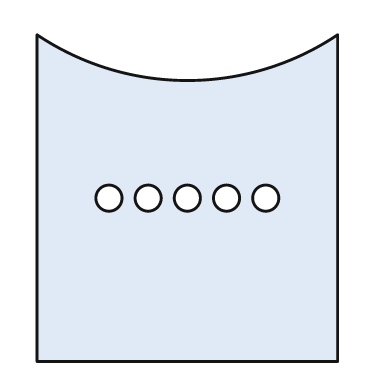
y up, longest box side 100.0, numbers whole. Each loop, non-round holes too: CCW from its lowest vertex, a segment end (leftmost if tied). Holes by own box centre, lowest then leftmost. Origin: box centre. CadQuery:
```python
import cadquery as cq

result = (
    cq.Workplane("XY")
    .moveTo(-46.0, -50.0)
    .lineTo(46.0, -50.0)
    .lineTo(46.0, 50.0)
    .threePointArc((0.0, 36.0), (-46.0, 50.0))
    .close()
    .moveTo(-24.0, 0.0)
    .circle(4.0)
    .moveTo(-12.0, 0.0)
    .circle(4.0)
    .moveTo(0.0, 0.0)
    .circle(4.0)
    .moveTo(12.0, 0.0)
    .circle(4.0)
    .moveTo(24.0, 0.0)
    .circle(4.0)
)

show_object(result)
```